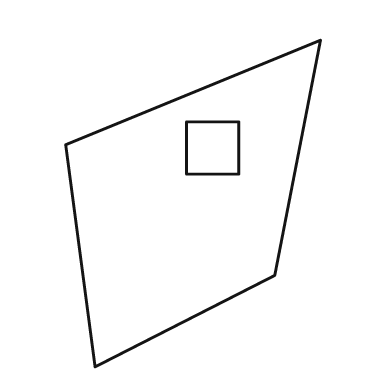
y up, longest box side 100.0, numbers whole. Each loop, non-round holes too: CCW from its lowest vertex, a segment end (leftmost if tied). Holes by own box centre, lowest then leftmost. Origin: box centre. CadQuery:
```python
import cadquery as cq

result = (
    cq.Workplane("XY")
    .moveTo(-30.0, -50.0)
    .lineTo(25.0, -22.0)
    .lineTo(39.0, 50.0)
    .lineTo(-39.0, 18.0)
    .close()
    .moveTo(-2.0, 9.0)
    .lineTo(14.0, 9.0)
    .lineTo(14.0, 25.0)
    .lineTo(-2.0, 25.0)
    .close()
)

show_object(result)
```